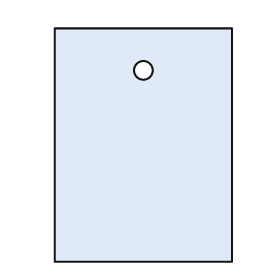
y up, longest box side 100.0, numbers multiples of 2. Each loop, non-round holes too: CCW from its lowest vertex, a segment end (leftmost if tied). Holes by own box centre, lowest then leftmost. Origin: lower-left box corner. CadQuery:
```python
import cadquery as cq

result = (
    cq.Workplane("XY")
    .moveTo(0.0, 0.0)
    .lineTo(76.0, 0.0)
    .lineTo(76.0, 100.0)
    .lineTo(0.0, 100.0)
    .close()
    .moveTo(38.0, 82.0)
    .circle(4.0)
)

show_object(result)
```